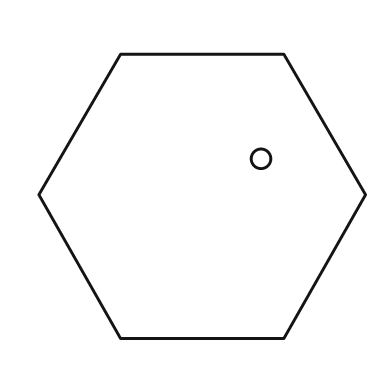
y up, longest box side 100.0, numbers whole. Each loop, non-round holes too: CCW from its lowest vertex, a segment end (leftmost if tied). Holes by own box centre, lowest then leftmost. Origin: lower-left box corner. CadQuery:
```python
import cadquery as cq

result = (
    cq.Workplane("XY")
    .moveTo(25.0, 0.0)
    .lineTo(75.0, 0.0)
    .lineTo(100.0, 44.0)
    .lineTo(75.0, 87.0)
    .lineTo(25.0, 87.0)
    .lineTo(0.0, 44.0)
    .close()
    .moveTo(68.0, 55.0)
    .circle(3.0)
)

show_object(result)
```